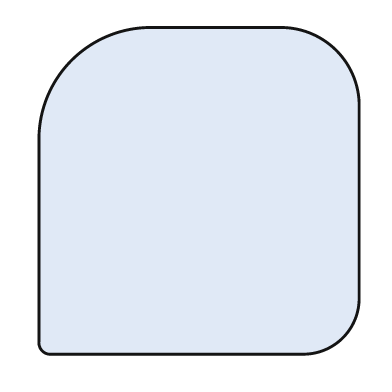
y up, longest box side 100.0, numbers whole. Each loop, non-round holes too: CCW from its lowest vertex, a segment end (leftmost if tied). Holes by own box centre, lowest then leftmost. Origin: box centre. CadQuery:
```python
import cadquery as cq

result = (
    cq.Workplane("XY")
    .moveTo(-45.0, -50.0)
    .lineTo(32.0, -50.0)
    .threePointArc((44.0, -45.0), (49.0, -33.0))
    .lineTo(49.0, 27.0)
    .threePointArc((42.0, 43.0), (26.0, 50.0))
    .lineTo(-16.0, 50.0)
    .threePointArc((-39.0, 40.0), (-49.0, 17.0))
    .lineTo(-49.0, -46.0)
    .threePointArc((-48.0, -49.0), (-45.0, -50.0))
    .close()
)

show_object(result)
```